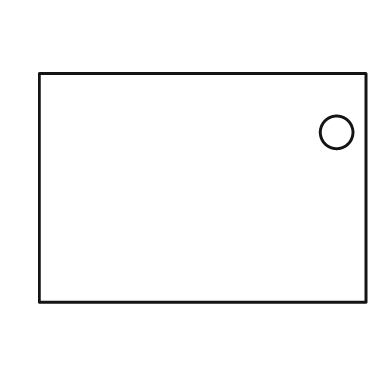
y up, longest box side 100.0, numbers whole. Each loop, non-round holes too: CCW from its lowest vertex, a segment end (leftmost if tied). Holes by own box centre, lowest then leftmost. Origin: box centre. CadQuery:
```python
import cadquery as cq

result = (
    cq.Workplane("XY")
    .moveTo(-50.0, -35.0)
    .lineTo(50.0, -35.0)
    .lineTo(50.0, 35.0)
    .lineTo(-50.0, 35.0)
    .close()
    .moveTo(41.0, 17.0)
    .circle(5.0)
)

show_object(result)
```